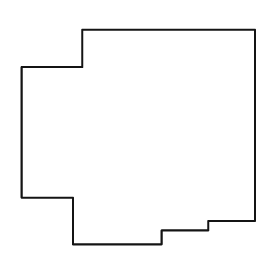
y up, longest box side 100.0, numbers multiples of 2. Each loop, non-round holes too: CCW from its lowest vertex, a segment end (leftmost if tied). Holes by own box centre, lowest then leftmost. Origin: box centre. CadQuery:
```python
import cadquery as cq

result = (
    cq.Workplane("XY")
    .moveTo(-28.0, -46.0)
    .lineTo(10.0, -46.0)
    .lineTo(10.0, -40.0)
    .lineTo(30.0, -40.0)
    .lineTo(30.0, -36.0)
    .lineTo(50.0, -36.0)
    .lineTo(50.0, 46.0)
    .lineTo(-24.0, 46.0)
    .lineTo(-24.0, 30.0)
    .lineTo(-50.0, 30.0)
    .lineTo(-50.0, -26.0)
    .lineTo(-28.0, -26.0)
    .close()
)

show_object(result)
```